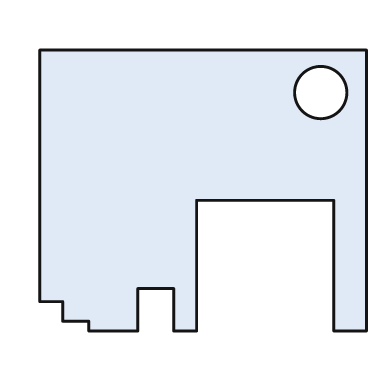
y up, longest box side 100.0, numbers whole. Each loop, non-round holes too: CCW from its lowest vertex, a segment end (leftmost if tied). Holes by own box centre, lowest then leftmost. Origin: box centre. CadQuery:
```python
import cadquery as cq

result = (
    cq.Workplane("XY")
    .moveTo(-35.0, -43.0)
    .lineTo(-20.0, -43.0)
    .lineTo(-20.0, -30.0)
    .lineTo(-9.0, -30.0)
    .lineTo(-9.0, -43.0)
    .lineTo(-2.0, -43.0)
    .lineTo(-2.0, -3.0)
    .lineTo(40.0, -3.0)
    .lineTo(40.0, -43.0)
    .lineTo(50.0, -43.0)
    .lineTo(50.0, 43.0)
    .lineTo(-50.0, 43.0)
    .lineTo(-50.0, -34.0)
    .lineTo(-43.0, -34.0)
    .lineTo(-43.0, -40.0)
    .lineTo(-35.0, -40.0)
    .close()
    .moveTo(36.0, 30.0)
    .circle(8.0)
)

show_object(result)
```